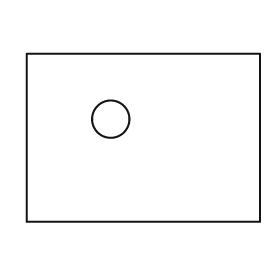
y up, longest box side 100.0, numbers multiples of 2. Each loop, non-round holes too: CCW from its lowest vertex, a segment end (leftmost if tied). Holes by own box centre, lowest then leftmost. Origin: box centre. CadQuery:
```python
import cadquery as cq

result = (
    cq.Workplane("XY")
    .moveTo(-50.0, -36.0)
    .lineTo(50.0, -36.0)
    .lineTo(50.0, 36.0)
    .lineTo(-50.0, 36.0)
    .close()
    .moveTo(-14.0, 8.0)
    .circle(8.0)
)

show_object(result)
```